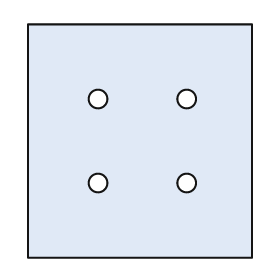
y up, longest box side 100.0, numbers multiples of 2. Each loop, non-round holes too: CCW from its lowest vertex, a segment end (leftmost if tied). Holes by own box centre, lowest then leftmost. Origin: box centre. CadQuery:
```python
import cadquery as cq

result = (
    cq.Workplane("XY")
    .moveTo(-48.0, -50.0)
    .lineTo(48.0, -50.0)
    .lineTo(48.0, 50.0)
    .lineTo(-48.0, 50.0)
    .close()
    .moveTo(-18.0, -18.0)
    .circle(4.0)
    .moveTo(20.0, -18.0)
    .circle(4.0)
    .moveTo(-18.0, 18.0)
    .circle(4.0)
    .moveTo(20.0, 18.0)
    .circle(4.0)
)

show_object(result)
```